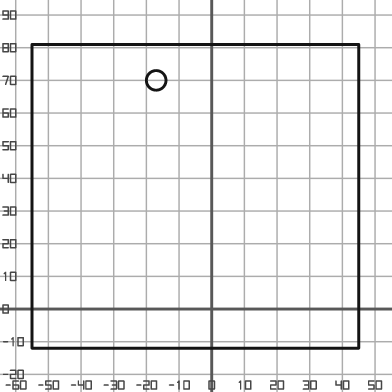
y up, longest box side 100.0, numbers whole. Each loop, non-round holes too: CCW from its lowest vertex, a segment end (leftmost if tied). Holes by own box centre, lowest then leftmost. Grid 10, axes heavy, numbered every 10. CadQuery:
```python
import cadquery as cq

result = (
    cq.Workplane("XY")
    .moveTo(-55.0, -12.0)
    .lineTo(45.0, -12.0)
    .lineTo(45.0, 81.0)
    .lineTo(-55.0, 81.0)
    .close()
    .moveTo(-17.0, 70.0)
    .circle(3.0)
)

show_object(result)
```